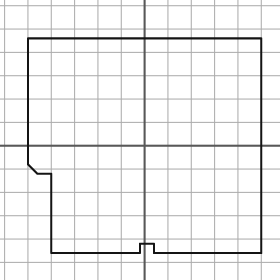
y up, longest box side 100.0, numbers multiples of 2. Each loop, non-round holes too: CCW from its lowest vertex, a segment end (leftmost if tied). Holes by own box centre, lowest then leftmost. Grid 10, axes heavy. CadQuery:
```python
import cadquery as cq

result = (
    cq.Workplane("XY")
    .moveTo(-40.0, -46.0)
    .lineTo(-2.0, -46.0)
    .lineTo(-2.0, -42.0)
    .lineTo(4.0, -42.0)
    .lineTo(4.0, -46.0)
    .lineTo(50.0, -46.0)
    .lineTo(50.0, 46.0)
    .lineTo(-50.0, 46.0)
    .lineTo(-50.0, -8.0)
    .lineTo(-46.0, -12.0)
    .lineTo(-40.0, -12.0)
    .close()
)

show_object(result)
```